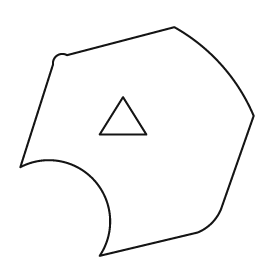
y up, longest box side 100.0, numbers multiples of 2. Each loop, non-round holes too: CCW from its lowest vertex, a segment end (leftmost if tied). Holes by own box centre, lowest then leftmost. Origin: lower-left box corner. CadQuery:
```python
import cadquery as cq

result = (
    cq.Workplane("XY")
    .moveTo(34.0, 0.0)
    .lineTo(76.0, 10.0)
    .threePointArc((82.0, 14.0), (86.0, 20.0))
    .lineTo(100.0, 60.0)
    .threePointArc((86.0, 82.0), (66.0, 98.0))
    .lineTo(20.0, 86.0)
    .threePointArc((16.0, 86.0), (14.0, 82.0))
    .lineTo(0.0, 38.0)
    .threePointArc((32.0, 32.0), (34.0, 0.0))
    .close()
    .moveTo(34.0, 52.0)
    .lineTo(54.0, 52.0)
    .lineTo(44.0, 68.0)
    .close()
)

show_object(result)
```